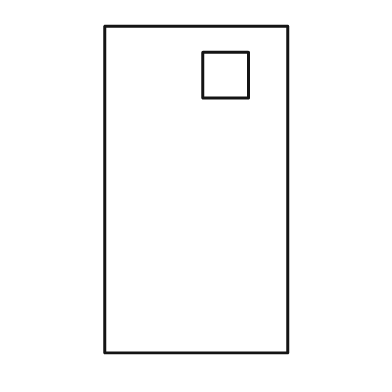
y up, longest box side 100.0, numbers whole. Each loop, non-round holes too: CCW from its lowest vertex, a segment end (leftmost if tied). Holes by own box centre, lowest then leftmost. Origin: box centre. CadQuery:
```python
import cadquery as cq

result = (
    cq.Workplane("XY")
    .moveTo(-28.0, -50.0)
    .lineTo(28.0, -50.0)
    .lineTo(28.0, 50.0)
    .lineTo(-28.0, 50.0)
    .close()
    .moveTo(2.0, 28.0)
    .lineTo(16.0, 28.0)
    .lineTo(16.0, 42.0)
    .lineTo(2.0, 42.0)
    .close()
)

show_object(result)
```